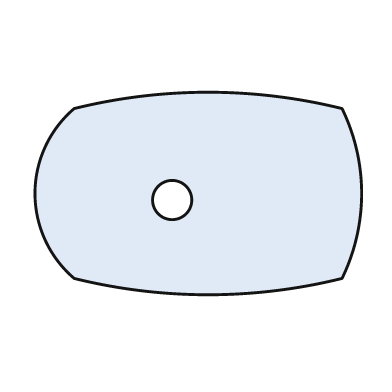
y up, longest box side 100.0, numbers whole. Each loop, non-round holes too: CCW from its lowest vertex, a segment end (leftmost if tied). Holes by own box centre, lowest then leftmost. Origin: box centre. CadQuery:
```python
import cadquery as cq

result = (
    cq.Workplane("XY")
    .moveTo(-38.0, -26.0)
    .threePointArc((3.0, -31.0), (44.0, -26.0))
    .threePointArc((50.0, 0.0), (44.0, 26.0))
    .threePointArc((3.0, 31.0), (-38.0, 26.0))
    .threePointArc((-50.0, 0.0), (-38.0, -26.0))
    .close()
    .moveTo(-8.0, -2.0)
    .circle(6.0)
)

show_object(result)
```